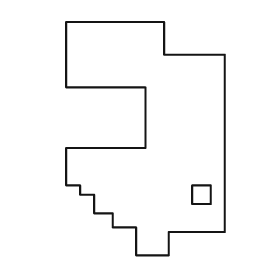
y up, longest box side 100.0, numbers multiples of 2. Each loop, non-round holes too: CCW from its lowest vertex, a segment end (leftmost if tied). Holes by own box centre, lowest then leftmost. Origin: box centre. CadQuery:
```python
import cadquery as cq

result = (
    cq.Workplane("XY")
    .moveTo(-4.0, -50.0)
    .lineTo(10.0, -50.0)
    .lineTo(10.0, -40.0)
    .lineTo(34.0, -40.0)
    .lineTo(34.0, 36.0)
    .lineTo(8.0, 36.0)
    .lineTo(8.0, 50.0)
    .lineTo(-34.0, 50.0)
    .lineTo(-34.0, 22.0)
    .lineTo(0.0, 22.0)
    .lineTo(0.0, -4.0)
    .lineTo(-34.0, -4.0)
    .lineTo(-34.0, -20.0)
    .lineTo(-28.0, -20.0)
    .lineTo(-28.0, -24.0)
    .lineTo(-22.0, -24.0)
    .lineTo(-22.0, -32.0)
    .lineTo(-14.0, -32.0)
    .lineTo(-14.0, -38.0)
    .lineTo(-4.0, -38.0)
    .close()
    .moveTo(20.0, -28.0)
    .lineTo(28.0, -28.0)
    .lineTo(28.0, -20.0)
    .lineTo(20.0, -20.0)
    .close()
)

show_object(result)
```